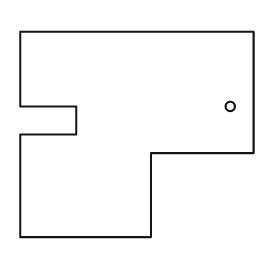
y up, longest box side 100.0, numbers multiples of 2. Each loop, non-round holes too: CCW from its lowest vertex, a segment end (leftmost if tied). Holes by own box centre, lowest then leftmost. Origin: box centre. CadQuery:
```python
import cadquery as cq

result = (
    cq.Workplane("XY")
    .moveTo(-50.0, -44.0)
    .lineTo(6.0, -44.0)
    .lineTo(6.0, -8.0)
    .lineTo(50.0, -8.0)
    .lineTo(50.0, 44.0)
    .lineTo(-50.0, 44.0)
    .lineTo(-50.0, 12.0)
    .lineTo(-26.0, 12.0)
    .lineTo(-26.0, 0.0)
    .lineTo(-50.0, 0.0)
    .close()
    .moveTo(40.0, 12.0)
    .circle(2.0)
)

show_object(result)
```